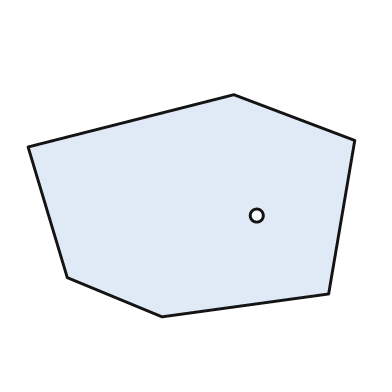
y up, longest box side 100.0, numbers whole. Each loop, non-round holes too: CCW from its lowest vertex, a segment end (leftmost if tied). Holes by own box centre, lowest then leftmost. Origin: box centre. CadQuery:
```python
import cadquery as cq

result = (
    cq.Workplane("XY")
    .moveTo(-9.0, -34.0)
    .lineTo(42.0, -27.0)
    .lineTo(50.0, 20.0)
    .lineTo(13.0, 34.0)
    .lineTo(-50.0, 18.0)
    .lineTo(-38.0, -22.0)
    .close()
    .moveTo(20.0, -3.0)
    .circle(2.0)
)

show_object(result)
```